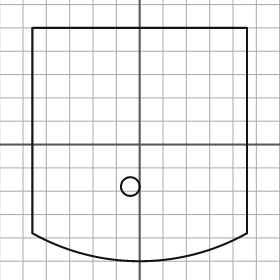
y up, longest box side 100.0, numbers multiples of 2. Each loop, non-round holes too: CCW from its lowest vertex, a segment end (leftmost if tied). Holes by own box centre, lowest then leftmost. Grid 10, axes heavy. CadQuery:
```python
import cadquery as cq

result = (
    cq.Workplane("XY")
    .moveTo(-46.0, -38.0)
    .threePointArc((0.0, -50.0), (46.0, -38.0))
    .lineTo(46.0, 50.0)
    .lineTo(-46.0, 50.0)
    .close()
    .moveTo(-4.0, -18.0)
    .circle(4.0)
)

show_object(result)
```